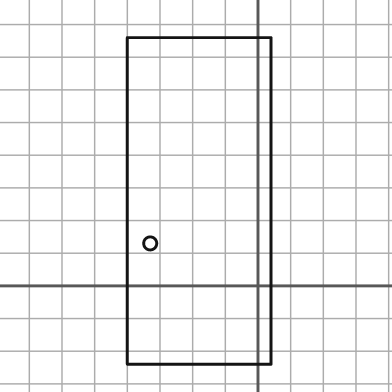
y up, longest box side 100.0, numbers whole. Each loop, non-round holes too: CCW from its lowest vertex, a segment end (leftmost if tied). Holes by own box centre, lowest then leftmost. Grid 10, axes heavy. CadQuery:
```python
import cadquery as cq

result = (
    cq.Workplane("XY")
    .moveTo(-40.0, -24.0)
    .lineTo(4.0, -24.0)
    .lineTo(4.0, 76.0)
    .lineTo(-40.0, 76.0)
    .close()
    .moveTo(-33.0, 13.0)
    .circle(2.0)
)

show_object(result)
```